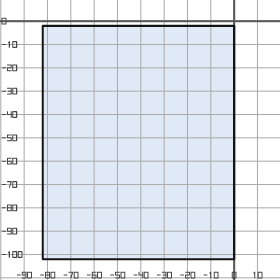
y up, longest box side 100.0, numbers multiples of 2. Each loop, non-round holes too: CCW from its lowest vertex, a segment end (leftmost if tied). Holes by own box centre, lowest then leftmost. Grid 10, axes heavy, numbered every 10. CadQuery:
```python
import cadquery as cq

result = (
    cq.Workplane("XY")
    .moveTo(-82.0, -102.0)
    .lineTo(0.0, -102.0)
    .lineTo(0.0, -2.0)
    .lineTo(-82.0, -2.0)
    .close()
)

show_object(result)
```